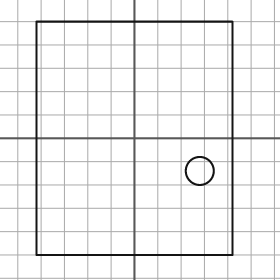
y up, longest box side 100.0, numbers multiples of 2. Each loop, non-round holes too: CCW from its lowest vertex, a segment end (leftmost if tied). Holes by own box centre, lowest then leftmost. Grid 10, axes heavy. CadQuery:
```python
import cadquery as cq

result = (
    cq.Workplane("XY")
    .moveTo(-42.0, -50.0)
    .lineTo(42.0, -50.0)
    .lineTo(42.0, 50.0)
    .lineTo(-42.0, 50.0)
    .close()
    .moveTo(28.0, -14.0)
    .circle(6.0)
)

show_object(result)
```